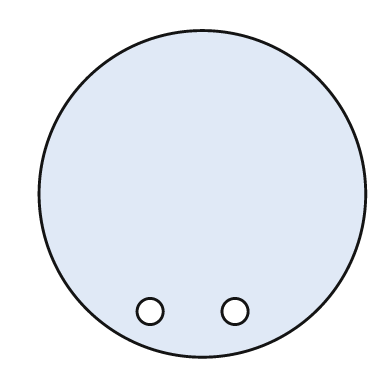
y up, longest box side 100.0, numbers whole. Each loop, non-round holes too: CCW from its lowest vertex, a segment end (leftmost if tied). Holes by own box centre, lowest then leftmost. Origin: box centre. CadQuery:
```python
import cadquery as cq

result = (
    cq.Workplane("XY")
    .moveTo(0.0, 0.0)
    .circle(50.0)
    .moveTo(-16.0, -36.0)
    .circle(4.0)
    .moveTo(10.0, -36.0)
    .circle(4.0)
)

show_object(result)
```